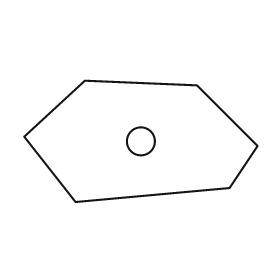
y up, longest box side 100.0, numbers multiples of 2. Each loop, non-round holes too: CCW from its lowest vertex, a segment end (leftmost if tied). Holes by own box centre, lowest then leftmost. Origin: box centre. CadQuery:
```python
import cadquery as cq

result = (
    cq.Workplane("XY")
    .moveTo(-28.0, -26.0)
    .lineTo(38.0, -20.0)
    .lineTo(50.0, -2.0)
    .lineTo(24.0, 24.0)
    .lineTo(-24.0, 26.0)
    .lineTo(-50.0, 2.0)
    .close()
    .moveTo(0.0, 0.0)
    .circle(6.0)
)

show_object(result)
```